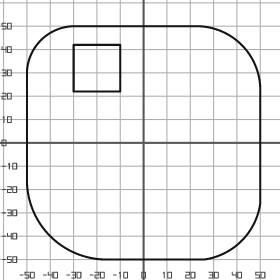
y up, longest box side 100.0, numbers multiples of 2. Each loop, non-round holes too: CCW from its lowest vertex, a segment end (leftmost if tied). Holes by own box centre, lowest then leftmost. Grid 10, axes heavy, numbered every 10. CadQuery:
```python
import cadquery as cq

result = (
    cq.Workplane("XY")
    .moveTo(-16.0, -50.0)
    .lineTo(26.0, -50.0)
    .threePointArc((42.0, -42.0), (50.0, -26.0))
    .lineTo(50.0, 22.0)
    .threePointArc((42.0, 42.0), (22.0, 50.0))
    .lineTo(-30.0, 50.0)
    .threePointArc((-44.0, 44.0), (-50.0, 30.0))
    .lineTo(-50.0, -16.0)
    .threePointArc((-40.0, -40.0), (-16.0, -50.0))
    .close()
    .moveTo(-30.0, 22.0)
    .lineTo(-10.0, 22.0)
    .lineTo(-10.0, 42.0)
    .lineTo(-30.0, 42.0)
    .close()
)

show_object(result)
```